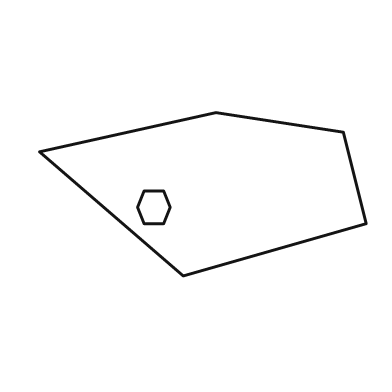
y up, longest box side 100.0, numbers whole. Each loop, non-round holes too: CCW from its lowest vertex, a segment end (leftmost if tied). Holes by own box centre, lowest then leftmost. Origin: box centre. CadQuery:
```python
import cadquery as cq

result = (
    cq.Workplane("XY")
    .moveTo(-6.0, -25.0)
    .lineTo(50.0, -9.0)
    .lineTo(43.0, 19.0)
    .lineTo(4.0, 25.0)
    .lineTo(-50.0, 13.0)
    .close()
    .moveTo(-18.0, -9.0)
    .lineTo(-12.0, -9.0)
    .lineTo(-10.0, -4.0)
    .lineTo(-12.0, 1.0)
    .lineTo(-18.0, 1.0)
    .lineTo(-20.0, -4.0)
    .close()
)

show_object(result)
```